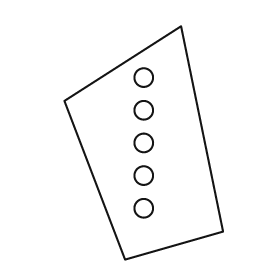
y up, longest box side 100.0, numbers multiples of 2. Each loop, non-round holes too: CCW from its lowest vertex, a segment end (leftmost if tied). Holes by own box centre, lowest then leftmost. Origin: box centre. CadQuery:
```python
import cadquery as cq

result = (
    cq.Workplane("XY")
    .moveTo(-8.0, -50.0)
    .lineTo(34.0, -38.0)
    .lineTo(16.0, 50.0)
    .lineTo(-34.0, 18.0)
    .close()
    .moveTo(0.0, -28.0)
    .circle(4.0)
    .moveTo(0.0, -14.0)
    .circle(4.0)
    .moveTo(0.0, 0.0)
    .circle(4.0)
    .moveTo(0.0, 14.0)
    .circle(4.0)
    .moveTo(0.0, 28.0)
    .circle(4.0)
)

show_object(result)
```